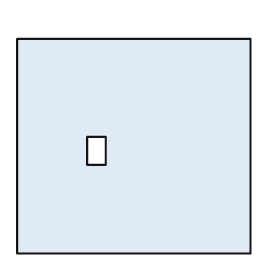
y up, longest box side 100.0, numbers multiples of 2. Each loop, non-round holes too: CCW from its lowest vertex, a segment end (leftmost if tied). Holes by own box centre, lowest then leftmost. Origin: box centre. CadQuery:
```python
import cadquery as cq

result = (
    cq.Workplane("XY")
    .moveTo(-50.0, -46.0)
    .lineTo(50.0, -46.0)
    .lineTo(50.0, 46.0)
    .lineTo(-50.0, 46.0)
    .close()
    .moveTo(-20.0, -8.0)
    .lineTo(-12.0, -8.0)
    .lineTo(-12.0, 4.0)
    .lineTo(-20.0, 4.0)
    .close()
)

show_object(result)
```